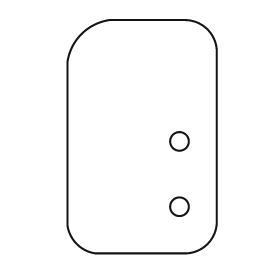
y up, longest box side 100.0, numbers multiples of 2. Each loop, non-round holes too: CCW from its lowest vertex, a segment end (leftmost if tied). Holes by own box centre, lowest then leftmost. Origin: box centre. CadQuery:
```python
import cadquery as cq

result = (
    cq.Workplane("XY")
    .moveTo(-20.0, -50.0)
    .lineTo(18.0, -50.0)
    .threePointArc((28.0, -46.0), (32.0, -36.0))
    .lineTo(32.0, 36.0)
    .threePointArc((28.0, 46.0), (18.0, 50.0))
    .lineTo(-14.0, 50.0)
    .threePointArc((-26.0, 44.0), (-32.0, 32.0))
    .lineTo(-32.0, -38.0)
    .threePointArc((-28.0, -46.0), (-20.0, -50.0))
    .close()
    .moveTo(16.0, -30.0)
    .circle(4.0)
    .moveTo(16.0, -2.0)
    .circle(4.0)
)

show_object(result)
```